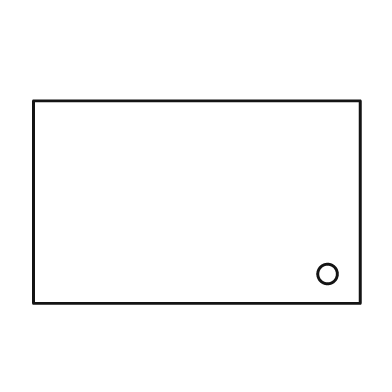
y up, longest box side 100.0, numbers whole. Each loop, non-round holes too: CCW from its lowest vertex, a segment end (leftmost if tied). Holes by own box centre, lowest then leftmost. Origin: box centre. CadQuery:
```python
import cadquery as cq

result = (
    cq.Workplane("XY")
    .moveTo(-50.0, -31.0)
    .lineTo(50.0, -31.0)
    .lineTo(50.0, 31.0)
    .lineTo(-50.0, 31.0)
    .close()
    .moveTo(40.0, -22.0)
    .circle(3.0)
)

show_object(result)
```